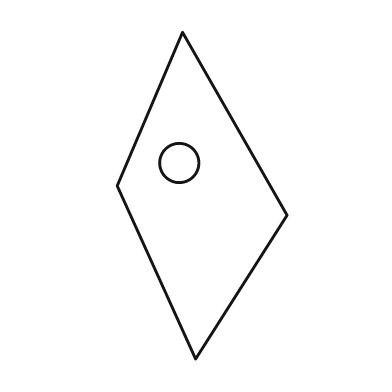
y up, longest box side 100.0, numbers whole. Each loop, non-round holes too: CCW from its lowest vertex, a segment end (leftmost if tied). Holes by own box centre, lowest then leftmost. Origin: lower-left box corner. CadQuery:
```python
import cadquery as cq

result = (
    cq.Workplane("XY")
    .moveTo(24.0, 0.0)
    .lineTo(52.0, 44.0)
    .lineTo(20.0, 100.0)
    .lineTo(0.0, 53.0)
    .close()
    .moveTo(19.0, 60.0)
    .circle(6.0)
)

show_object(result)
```